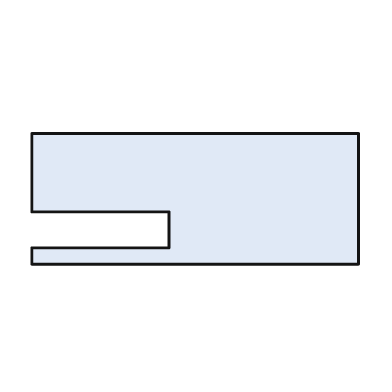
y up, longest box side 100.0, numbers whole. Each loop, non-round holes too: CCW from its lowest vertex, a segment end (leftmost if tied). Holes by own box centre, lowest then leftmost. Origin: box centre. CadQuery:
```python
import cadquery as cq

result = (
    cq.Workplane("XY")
    .moveTo(-50.0, -20.0)
    .lineTo(50.0, -20.0)
    .lineTo(50.0, 20.0)
    .lineTo(-50.0, 20.0)
    .lineTo(-50.0, -4.0)
    .lineTo(-8.0, -4.0)
    .lineTo(-8.0, -15.0)
    .lineTo(-50.0, -15.0)
    .close()
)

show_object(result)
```